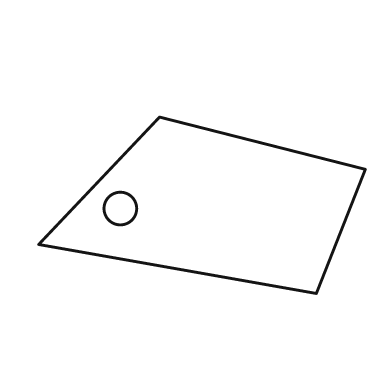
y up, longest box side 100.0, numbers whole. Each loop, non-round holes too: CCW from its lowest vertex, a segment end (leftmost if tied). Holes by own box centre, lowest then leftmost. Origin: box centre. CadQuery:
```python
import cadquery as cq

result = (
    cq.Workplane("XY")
    .moveTo(35.0, -27.0)
    .lineTo(50.0, 11.0)
    .lineTo(-13.0, 27.0)
    .lineTo(-50.0, -12.0)
    .close()
    .moveTo(-25.0, -1.0)
    .circle(5.0)
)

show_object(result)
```